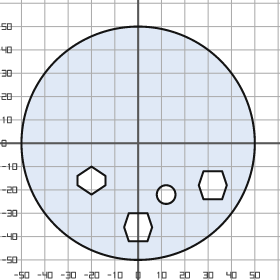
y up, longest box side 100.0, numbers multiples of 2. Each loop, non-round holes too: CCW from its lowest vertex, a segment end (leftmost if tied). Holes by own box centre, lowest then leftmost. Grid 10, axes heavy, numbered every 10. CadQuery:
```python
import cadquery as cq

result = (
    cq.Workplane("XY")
    .moveTo(0.0, 0.0)
    .circle(50.0)
    .moveTo(-4.0, -42.0)
    .lineTo(4.0, -42.0)
    .lineTo(6.0, -36.0)
    .lineTo(4.0, -30.0)
    .lineTo(-4.0, -30.0)
    .lineTo(-6.0, -36.0)
    .close()
    .moveTo(12.0, -22.0)
    .circle(4.0)
    .moveTo(28.0, -24.0)
    .lineTo(36.0, -24.0)
    .lineTo(38.0, -18.0)
    .lineTo(36.0, -12.0)
    .lineTo(28.0, -12.0)
    .lineTo(26.0, -18.0)
    .close()
    .moveTo(-20.0, -22.0)
    .lineTo(-14.0, -18.0)
    .lineTo(-14.0, -14.0)
    .lineTo(-20.0, -10.0)
    .lineTo(-26.0, -14.0)
    .lineTo(-26.0, -18.0)
    .close()
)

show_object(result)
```